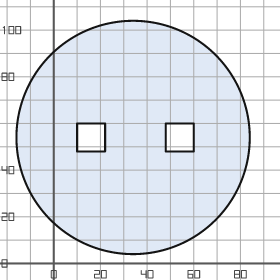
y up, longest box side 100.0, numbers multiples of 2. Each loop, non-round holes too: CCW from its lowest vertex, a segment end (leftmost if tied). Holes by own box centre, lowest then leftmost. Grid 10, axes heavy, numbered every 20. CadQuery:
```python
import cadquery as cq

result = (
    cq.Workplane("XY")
    .moveTo(34.0, 54.0)
    .circle(50.0)
    .moveTo(10.0, 48.0)
    .lineTo(22.0, 48.0)
    .lineTo(22.0, 60.0)
    .lineTo(10.0, 60.0)
    .close()
    .moveTo(48.0, 48.0)
    .lineTo(60.0, 48.0)
    .lineTo(60.0, 60.0)
    .lineTo(48.0, 60.0)
    .close()
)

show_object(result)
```